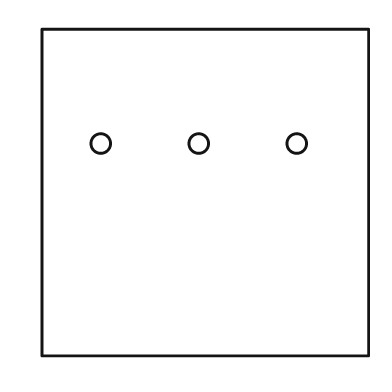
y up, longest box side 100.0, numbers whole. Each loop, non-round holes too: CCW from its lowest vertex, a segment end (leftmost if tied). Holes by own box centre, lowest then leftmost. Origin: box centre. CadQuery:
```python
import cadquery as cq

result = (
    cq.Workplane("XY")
    .moveTo(-50.0, -50.0)
    .lineTo(50.0, -50.0)
    .lineTo(50.0, 50.0)
    .lineTo(-50.0, 50.0)
    .close()
    .moveTo(-32.0, 15.0)
    .circle(3.0)
    .moveTo(-2.0, 15.0)
    .circle(3.0)
    .moveTo(28.0, 15.0)
    .circle(3.0)
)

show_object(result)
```